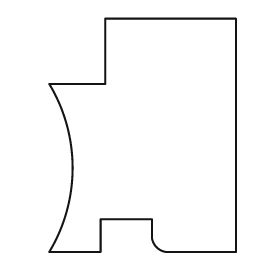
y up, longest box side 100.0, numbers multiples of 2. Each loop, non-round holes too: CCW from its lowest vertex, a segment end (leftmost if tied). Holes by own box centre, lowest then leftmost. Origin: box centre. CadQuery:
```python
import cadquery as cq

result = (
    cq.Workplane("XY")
    .moveTo(-40.0, -50.0)
    .lineTo(-18.0, -50.0)
    .lineTo(-18.0, -36.0)
    .lineTo(4.0, -36.0)
    .lineTo(4.0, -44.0)
    .threePointArc((6.0, -48.0), (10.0, -50.0))
    .lineTo(40.0, -50.0)
    .lineTo(40.0, 50.0)
    .lineTo(-16.0, 50.0)
    .lineTo(-16.0, 22.0)
    .lineTo(-40.0, 22.0)
    .threePointArc((-30.0, -14.0), (-40.0, -50.0))
    .close()
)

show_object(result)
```